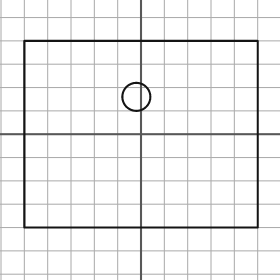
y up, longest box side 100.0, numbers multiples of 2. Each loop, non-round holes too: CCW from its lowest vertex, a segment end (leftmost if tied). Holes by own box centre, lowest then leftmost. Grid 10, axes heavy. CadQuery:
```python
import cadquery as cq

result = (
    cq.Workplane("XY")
    .moveTo(-50.0, -40.0)
    .lineTo(50.0, -40.0)
    .lineTo(50.0, 40.0)
    .lineTo(-50.0, 40.0)
    .close()
    .moveTo(-2.0, 16.0)
    .circle(6.0)
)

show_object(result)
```